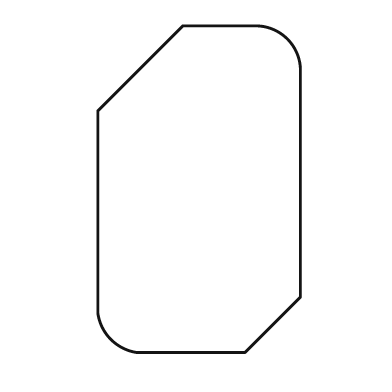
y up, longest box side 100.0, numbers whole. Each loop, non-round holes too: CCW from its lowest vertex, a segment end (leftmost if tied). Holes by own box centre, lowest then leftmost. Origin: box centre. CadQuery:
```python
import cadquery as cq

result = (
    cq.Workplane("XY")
    .moveTo(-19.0, -50.0)
    .lineTo(14.0, -50.0)
    .lineTo(31.0, -33.0)
    .lineTo(31.0, 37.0)
    .threePointArc((27.0, 46.0), (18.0, 50.0))
    .lineTo(-5.0, 50.0)
    .lineTo(-31.0, 24.0)
    .lineTo(-31.0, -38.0)
    .threePointArc((-27.0, -46.0), (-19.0, -50.0))
    .close()
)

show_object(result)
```